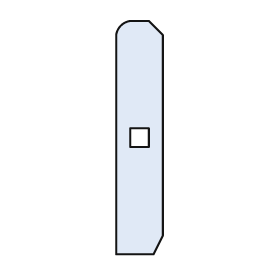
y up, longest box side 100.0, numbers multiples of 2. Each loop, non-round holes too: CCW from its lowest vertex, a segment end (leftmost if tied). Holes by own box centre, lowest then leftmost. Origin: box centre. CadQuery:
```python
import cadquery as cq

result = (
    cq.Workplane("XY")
    .moveTo(-10.0, -50.0)
    .lineTo(6.0, -50.0)
    .lineTo(10.0, -42.0)
    .lineTo(10.0, 44.0)
    .lineTo(4.0, 50.0)
    .lineTo(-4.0, 50.0)
    .threePointArc((-8.0, 48.0), (-10.0, 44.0))
    .close()
    .moveTo(-4.0, -4.0)
    .lineTo(4.0, -4.0)
    .lineTo(4.0, 4.0)
    .lineTo(-4.0, 4.0)
    .close()
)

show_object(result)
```